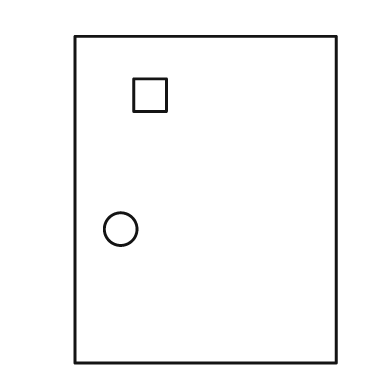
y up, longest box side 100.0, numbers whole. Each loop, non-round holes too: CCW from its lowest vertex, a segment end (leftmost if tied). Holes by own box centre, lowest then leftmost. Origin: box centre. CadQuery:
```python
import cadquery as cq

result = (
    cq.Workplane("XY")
    .moveTo(-40.0, -50.0)
    .lineTo(40.0, -50.0)
    .lineTo(40.0, 50.0)
    .lineTo(-40.0, 50.0)
    .close()
    .moveTo(-26.0, -9.0)
    .circle(5.0)
    .moveTo(-22.0, 27.0)
    .lineTo(-12.0, 27.0)
    .lineTo(-12.0, 37.0)
    .lineTo(-22.0, 37.0)
    .close()
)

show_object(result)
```